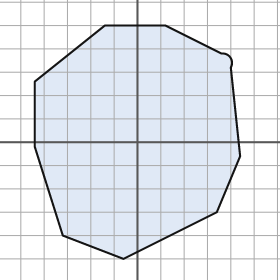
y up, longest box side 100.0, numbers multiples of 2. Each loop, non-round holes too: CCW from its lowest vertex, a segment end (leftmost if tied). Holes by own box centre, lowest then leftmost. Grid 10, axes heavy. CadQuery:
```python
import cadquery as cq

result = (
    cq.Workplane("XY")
    .moveTo(-6.0, -50.0)
    .lineTo(34.0, -30.0)
    .lineTo(44.0, -6.0)
    .lineTo(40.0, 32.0)
    .threePointArc((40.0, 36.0), (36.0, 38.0))
    .lineTo(12.0, 50.0)
    .lineTo(-14.0, 50.0)
    .lineTo(-44.0, 26.0)
    .lineTo(-44.0, -2.0)
    .lineTo(-32.0, -40.0)
    .close()
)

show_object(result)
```